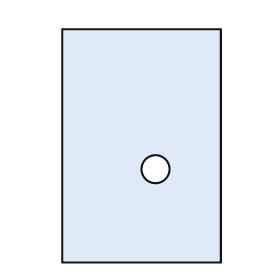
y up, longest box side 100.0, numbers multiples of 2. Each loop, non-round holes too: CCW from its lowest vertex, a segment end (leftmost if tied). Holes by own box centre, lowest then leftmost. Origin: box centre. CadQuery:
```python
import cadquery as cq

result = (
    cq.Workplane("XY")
    .moveTo(-34.0, -50.0)
    .lineTo(34.0, -50.0)
    .lineTo(34.0, 50.0)
    .lineTo(-34.0, 50.0)
    .close()
    .moveTo(6.0, -10.0)
    .circle(6.0)
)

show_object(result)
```